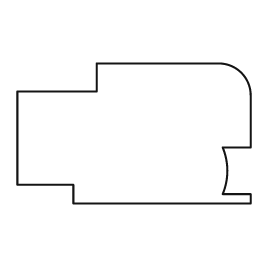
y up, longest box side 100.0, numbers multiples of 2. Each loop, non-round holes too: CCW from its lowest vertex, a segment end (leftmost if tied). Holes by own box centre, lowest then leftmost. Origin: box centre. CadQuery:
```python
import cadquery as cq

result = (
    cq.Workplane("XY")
    .moveTo(-26.0, -30.0)
    .lineTo(50.0, -30.0)
    .lineTo(50.0, -26.0)
    .lineTo(38.0, -26.0)
    .threePointArc((40.0, -16.0), (38.0, -6.0))
    .lineTo(50.0, -6.0)
    .lineTo(50.0, 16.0)
    .threePointArc((46.0, 26.0), (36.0, 30.0))
    .lineTo(-16.0, 30.0)
    .lineTo(-16.0, 18.0)
    .lineTo(-50.0, 18.0)
    .lineTo(-50.0, -22.0)
    .lineTo(-26.0, -22.0)
    .close()
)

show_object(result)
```